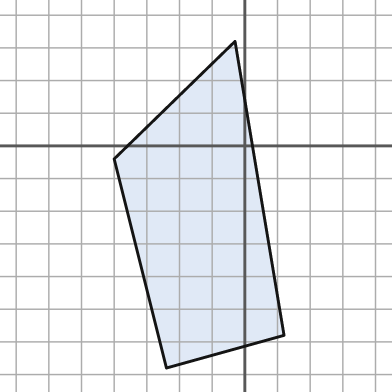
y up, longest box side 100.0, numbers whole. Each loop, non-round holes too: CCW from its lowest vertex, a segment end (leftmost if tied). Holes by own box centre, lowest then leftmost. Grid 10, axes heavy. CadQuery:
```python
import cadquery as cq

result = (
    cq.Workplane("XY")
    .moveTo(-24.0, -68.0)
    .lineTo(12.0, -58.0)
    .lineTo(-3.0, 32.0)
    .lineTo(-40.0, -4.0)
    .close()
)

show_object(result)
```